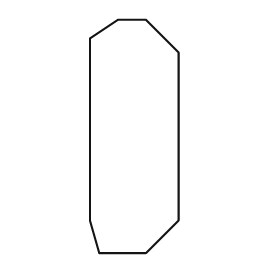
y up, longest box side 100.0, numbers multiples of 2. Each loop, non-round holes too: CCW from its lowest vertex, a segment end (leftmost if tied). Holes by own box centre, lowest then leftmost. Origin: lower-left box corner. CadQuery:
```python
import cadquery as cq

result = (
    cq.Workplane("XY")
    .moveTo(4.0, 0.0)
    .lineTo(24.0, 0.0)
    .lineTo(38.0, 14.0)
    .lineTo(38.0, 86.0)
    .lineTo(24.0, 100.0)
    .lineTo(12.0, 100.0)
    .lineTo(0.0, 92.0)
    .lineTo(0.0, 14.0)
    .close()
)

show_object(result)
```